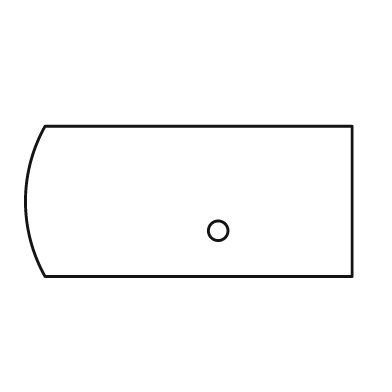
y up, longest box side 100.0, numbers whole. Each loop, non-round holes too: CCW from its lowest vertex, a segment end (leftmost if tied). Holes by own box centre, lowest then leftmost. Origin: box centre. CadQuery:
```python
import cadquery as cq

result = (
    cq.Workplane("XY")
    .moveTo(-44.0, -23.0)
    .lineTo(50.0, -23.0)
    .lineTo(50.0, 23.0)
    .lineTo(-44.0, 23.0)
    .threePointArc((-50.0, 0.0), (-44.0, -23.0))
    .close()
    .moveTo(9.0, -9.0)
    .circle(3.0)
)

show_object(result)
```